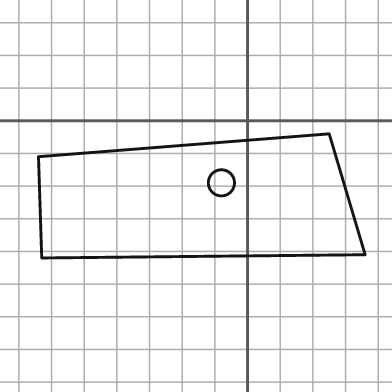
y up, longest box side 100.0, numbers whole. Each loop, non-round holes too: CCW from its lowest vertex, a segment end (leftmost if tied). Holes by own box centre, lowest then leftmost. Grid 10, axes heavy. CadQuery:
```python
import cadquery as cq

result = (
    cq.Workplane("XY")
    .moveTo(-63.0, -42.0)
    .lineTo(36.0, -41.0)
    .lineTo(25.0, -4.0)
    .lineTo(-64.0, -11.0)
    .close()
    .moveTo(-8.0, -19.0)
    .circle(4.0)
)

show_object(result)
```